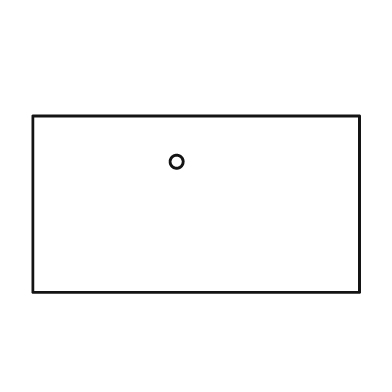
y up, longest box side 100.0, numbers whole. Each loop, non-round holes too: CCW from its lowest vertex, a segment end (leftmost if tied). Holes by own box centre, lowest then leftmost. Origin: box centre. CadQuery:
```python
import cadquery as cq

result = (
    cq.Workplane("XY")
    .moveTo(-50.0, -27.0)
    .lineTo(50.0, -27.0)
    .lineTo(50.0, 27.0)
    .lineTo(-50.0, 27.0)
    .close()
    .moveTo(-6.0, 13.0)
    .circle(2.0)
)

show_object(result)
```